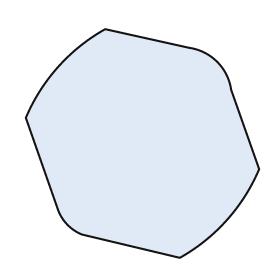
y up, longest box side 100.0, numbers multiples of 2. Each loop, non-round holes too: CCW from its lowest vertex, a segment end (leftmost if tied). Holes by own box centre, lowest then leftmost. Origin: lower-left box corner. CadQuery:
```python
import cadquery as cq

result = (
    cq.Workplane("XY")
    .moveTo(66.0, 0.0)
    .threePointArc((86.0, 16.0), (100.0, 38.0))
    .lineTo(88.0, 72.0)
    .threePointArc((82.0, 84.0), (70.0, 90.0))
    .lineTo(34.0, 98.0)
    .threePointArc((14.0, 82.0), (0.0, 60.0))
    .lineTo(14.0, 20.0)
    .threePointArc((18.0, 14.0), (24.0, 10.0))
    .close()
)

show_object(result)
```